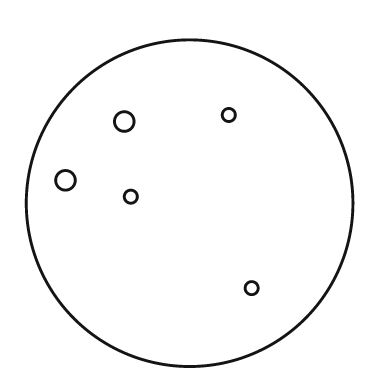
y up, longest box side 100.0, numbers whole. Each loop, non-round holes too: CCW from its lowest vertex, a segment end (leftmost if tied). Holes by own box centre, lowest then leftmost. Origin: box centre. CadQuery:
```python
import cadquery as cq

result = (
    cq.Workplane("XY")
    .moveTo(0.0, 0.0)
    .circle(50.0)
    .moveTo(19.0, -26.0)
    .circle(2.0)
    .moveTo(-18.0, 2.0)
    .circle(2.0)
    .moveTo(-38.0, 7.0)
    .circle(3.0)
    .moveTo(-20.0, 25.0)
    .circle(3.0)
    .moveTo(12.0, 27.0)
    .circle(2.0)
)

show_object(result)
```